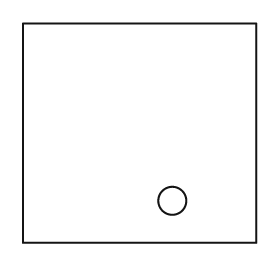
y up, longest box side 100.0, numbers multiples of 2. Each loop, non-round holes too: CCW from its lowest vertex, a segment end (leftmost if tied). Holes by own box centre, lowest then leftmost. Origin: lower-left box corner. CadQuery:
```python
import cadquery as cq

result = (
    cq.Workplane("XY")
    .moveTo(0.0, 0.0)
    .lineTo(100.0, 0.0)
    .lineTo(100.0, 94.0)
    .lineTo(0.0, 94.0)
    .close()
    .moveTo(64.0, 18.0)
    .circle(6.0)
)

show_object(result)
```